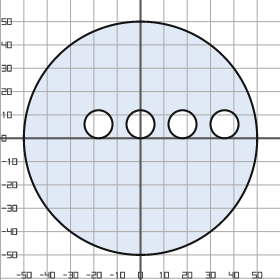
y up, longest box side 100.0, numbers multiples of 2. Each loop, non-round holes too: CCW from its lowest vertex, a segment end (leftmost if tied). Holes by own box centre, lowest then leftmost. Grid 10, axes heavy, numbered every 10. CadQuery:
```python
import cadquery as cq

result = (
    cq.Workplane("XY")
    .moveTo(0.0, 0.0)
    .circle(50.0)
    .moveTo(-18.0, 6.0)
    .circle(6.0)
    .moveTo(0.0, 6.0)
    .circle(6.0)
    .moveTo(18.0, 6.0)
    .circle(6.0)
    .moveTo(36.0, 6.0)
    .circle(6.0)
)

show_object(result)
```